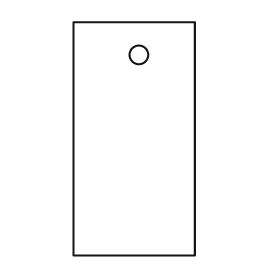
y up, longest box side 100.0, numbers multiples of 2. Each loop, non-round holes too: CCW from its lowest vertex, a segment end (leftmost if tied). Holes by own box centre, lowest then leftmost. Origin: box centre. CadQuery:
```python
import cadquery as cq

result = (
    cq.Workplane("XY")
    .moveTo(-26.0, -50.0)
    .lineTo(26.0, -50.0)
    .lineTo(26.0, 50.0)
    .lineTo(-26.0, 50.0)
    .close()
    .moveTo(2.0, 36.0)
    .circle(4.0)
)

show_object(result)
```